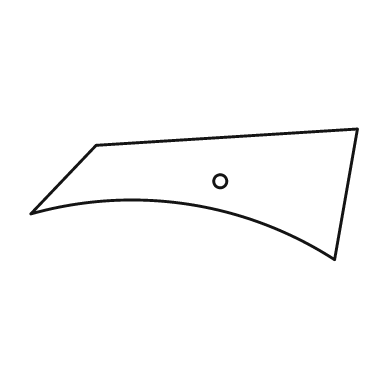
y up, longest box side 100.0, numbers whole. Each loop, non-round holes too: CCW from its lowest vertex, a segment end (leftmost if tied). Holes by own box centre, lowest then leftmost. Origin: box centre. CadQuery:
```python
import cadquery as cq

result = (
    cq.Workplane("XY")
    .moveTo(43.0, -20.0)
    .lineTo(50.0, 20.0)
    .lineTo(-30.0, 15.0)
    .lineTo(-50.0, -6.0)
    .threePointArc((-2.0, -3.0), (43.0, -20.0))
    .close()
    .moveTo(8.0, 4.0)
    .circle(2.0)
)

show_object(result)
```